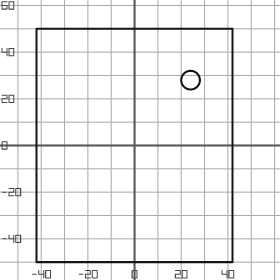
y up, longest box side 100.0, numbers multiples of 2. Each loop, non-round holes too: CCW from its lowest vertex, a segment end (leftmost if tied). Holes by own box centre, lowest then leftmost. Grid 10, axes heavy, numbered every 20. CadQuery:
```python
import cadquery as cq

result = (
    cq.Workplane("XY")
    .moveTo(-42.0, -50.0)
    .lineTo(42.0, -50.0)
    .lineTo(42.0, 50.0)
    .lineTo(-42.0, 50.0)
    .close()
    .moveTo(24.0, 28.0)
    .circle(4.0)
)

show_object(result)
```